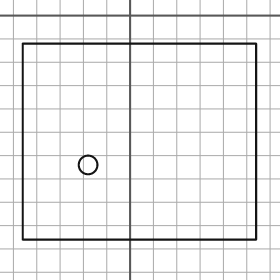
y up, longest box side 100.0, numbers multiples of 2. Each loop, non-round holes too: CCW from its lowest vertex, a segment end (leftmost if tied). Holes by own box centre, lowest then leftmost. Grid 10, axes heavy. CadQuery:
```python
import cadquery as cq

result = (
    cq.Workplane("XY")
    .moveTo(-46.0, -96.0)
    .lineTo(54.0, -96.0)
    .lineTo(54.0, -12.0)
    .lineTo(-46.0, -12.0)
    .close()
    .moveTo(-18.0, -64.0)
    .circle(4.0)
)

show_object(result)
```